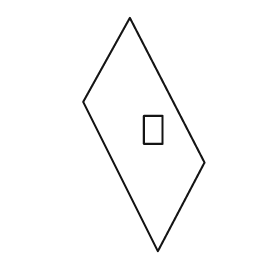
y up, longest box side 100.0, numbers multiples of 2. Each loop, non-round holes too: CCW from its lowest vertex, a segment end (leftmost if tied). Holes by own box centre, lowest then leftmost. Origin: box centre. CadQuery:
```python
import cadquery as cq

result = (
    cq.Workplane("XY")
    .moveTo(6.0, -50.0)
    .lineTo(26.0, -12.0)
    .lineTo(-6.0, 50.0)
    .lineTo(-26.0, 14.0)
    .close()
    .moveTo(0.0, -4.0)
    .lineTo(8.0, -4.0)
    .lineTo(8.0, 8.0)
    .lineTo(0.0, 8.0)
    .close()
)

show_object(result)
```